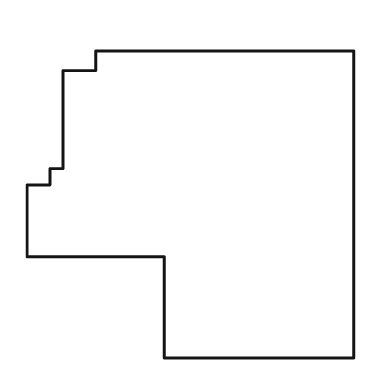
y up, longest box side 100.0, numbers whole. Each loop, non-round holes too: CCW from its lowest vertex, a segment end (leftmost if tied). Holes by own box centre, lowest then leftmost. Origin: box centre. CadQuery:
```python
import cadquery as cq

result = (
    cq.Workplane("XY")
    .moveTo(-8.0, -47.0)
    .lineTo(50.0, -47.0)
    .lineTo(50.0, 47.0)
    .lineTo(-29.0, 47.0)
    .lineTo(-29.0, 41.0)
    .lineTo(-39.0, 41.0)
    .lineTo(-39.0, 11.0)
    .lineTo(-43.0, 11.0)
    .lineTo(-43.0, 6.0)
    .lineTo(-50.0, 6.0)
    .lineTo(-50.0, -16.0)
    .lineTo(-8.0, -16.0)
    .close()
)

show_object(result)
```